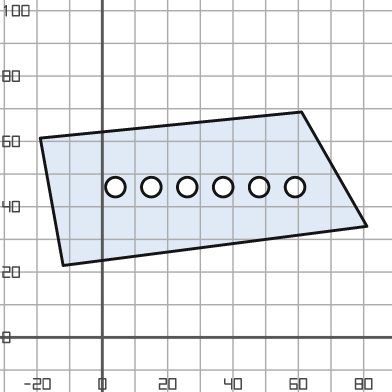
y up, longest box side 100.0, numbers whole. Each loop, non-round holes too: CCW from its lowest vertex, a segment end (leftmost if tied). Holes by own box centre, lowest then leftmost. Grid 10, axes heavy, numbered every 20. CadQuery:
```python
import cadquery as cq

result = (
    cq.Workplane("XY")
    .moveTo(-12.0, 22.0)
    .lineTo(81.0, 34.0)
    .lineTo(61.0, 69.0)
    .lineTo(-19.0, 61.0)
    .close()
    .moveTo(4.0, 46.0)
    .circle(3.0)
    .moveTo(15.0, 46.0)
    .circle(3.0)
    .moveTo(26.0, 46.0)
    .circle(3.0)
    .moveTo(37.0, 46.0)
    .circle(3.0)
    .moveTo(48.0, 46.0)
    .circle(3.0)
    .moveTo(59.0, 46.0)
    .circle(3.0)
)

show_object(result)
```